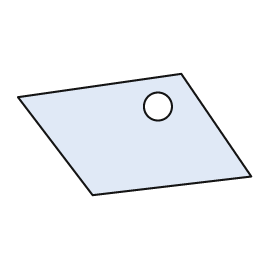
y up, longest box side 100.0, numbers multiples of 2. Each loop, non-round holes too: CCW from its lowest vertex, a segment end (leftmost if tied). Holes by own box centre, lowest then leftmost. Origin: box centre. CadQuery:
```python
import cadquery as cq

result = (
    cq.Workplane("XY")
    .moveTo(-18.0, -26.0)
    .lineTo(50.0, -18.0)
    .lineTo(20.0, 26.0)
    .lineTo(-50.0, 16.0)
    .close()
    .moveTo(10.0, 12.0)
    .circle(6.0)
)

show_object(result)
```